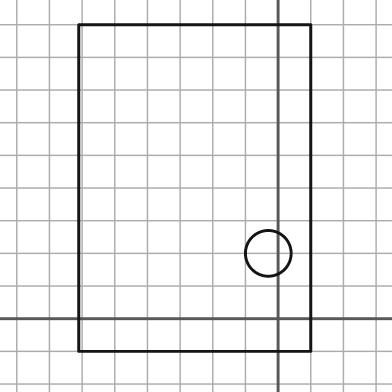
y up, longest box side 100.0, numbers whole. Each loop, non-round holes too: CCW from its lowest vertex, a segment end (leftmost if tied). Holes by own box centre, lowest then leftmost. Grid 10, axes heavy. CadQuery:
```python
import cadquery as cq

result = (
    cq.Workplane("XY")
    .moveTo(-61.0, -10.0)
    .lineTo(10.0, -10.0)
    .lineTo(10.0, 90.0)
    .lineTo(-61.0, 90.0)
    .close()
    .moveTo(-3.0, 20.0)
    .circle(7.0)
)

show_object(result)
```